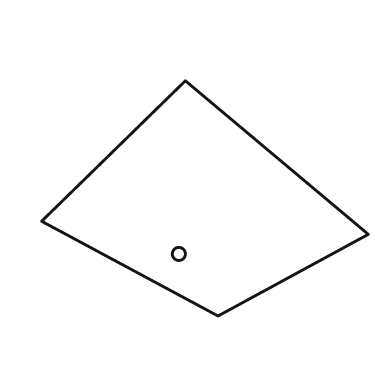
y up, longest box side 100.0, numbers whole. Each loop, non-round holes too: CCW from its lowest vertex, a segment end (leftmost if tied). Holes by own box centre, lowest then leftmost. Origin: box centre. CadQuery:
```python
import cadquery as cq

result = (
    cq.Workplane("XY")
    .moveTo(4.0, -36.0)
    .lineTo(50.0, -11.0)
    .lineTo(-6.0, 36.0)
    .lineTo(-50.0, -7.0)
    .close()
    .moveTo(-8.0, -17.0)
    .circle(2.0)
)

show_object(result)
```